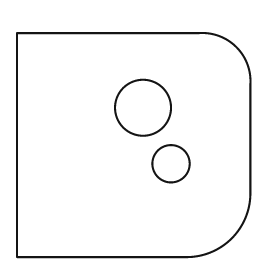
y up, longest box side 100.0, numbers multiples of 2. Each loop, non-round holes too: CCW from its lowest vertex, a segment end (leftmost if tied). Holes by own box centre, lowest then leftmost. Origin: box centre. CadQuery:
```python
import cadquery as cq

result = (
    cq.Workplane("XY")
    .moveTo(-50.0, -48.0)
    .lineTo(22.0, -48.0)
    .threePointArc((42.0, -40.0), (50.0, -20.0))
    .lineTo(50.0, 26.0)
    .threePointArc((44.0, 42.0), (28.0, 48.0))
    .lineTo(-50.0, 48.0)
    .close()
    .moveTo(16.0, -8.0)
    .circle(8.0)
    .moveTo(4.0, 16.0)
    .circle(12.0)
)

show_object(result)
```